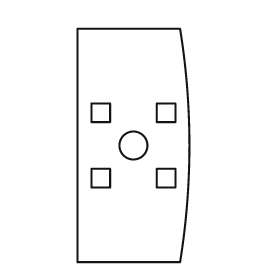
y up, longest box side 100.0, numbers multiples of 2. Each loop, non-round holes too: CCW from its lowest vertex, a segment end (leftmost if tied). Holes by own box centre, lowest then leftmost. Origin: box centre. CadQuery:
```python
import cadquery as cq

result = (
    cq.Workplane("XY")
    .moveTo(-24.0, -50.0)
    .lineTo(20.0, -50.0)
    .threePointArc((24.0, 0.0), (20.0, 50.0))
    .lineTo(-24.0, 50.0)
    .close()
    .moveTo(-18.0, -18.0)
    .lineTo(-10.0, -18.0)
    .lineTo(-10.0, -10.0)
    .lineTo(-18.0, -10.0)
    .close()
    .moveTo(10.0, -18.0)
    .lineTo(18.0, -18.0)
    .lineTo(18.0, -10.0)
    .lineTo(10.0, -10.0)
    .close()
    .moveTo(0.0, 0.0)
    .circle(6.0)
    .moveTo(-18.0, 10.0)
    .lineTo(-10.0, 10.0)
    .lineTo(-10.0, 18.0)
    .lineTo(-18.0, 18.0)
    .close()
    .moveTo(10.0, 10.0)
    .lineTo(18.0, 10.0)
    .lineTo(18.0, 18.0)
    .lineTo(10.0, 18.0)
    .close()
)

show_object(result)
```